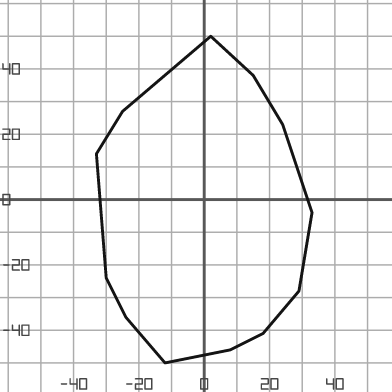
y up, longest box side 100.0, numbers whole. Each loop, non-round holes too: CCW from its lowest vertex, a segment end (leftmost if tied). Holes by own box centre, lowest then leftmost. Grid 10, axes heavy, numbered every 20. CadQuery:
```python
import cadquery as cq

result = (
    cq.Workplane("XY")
    .moveTo(-12.0, -50.0)
    .lineTo(8.0, -46.0)
    .lineTo(18.0, -41.0)
    .lineTo(29.0, -28.0)
    .lineTo(33.0, -4.0)
    .lineTo(24.0, 23.0)
    .lineTo(15.0, 38.0)
    .lineTo(2.0, 50.0)
    .lineTo(-25.0, 27.0)
    .lineTo(-33.0, 14.0)
    .lineTo(-30.0, -24.0)
    .lineTo(-24.0, -36.0)
    .close()
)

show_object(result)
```